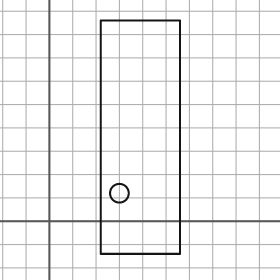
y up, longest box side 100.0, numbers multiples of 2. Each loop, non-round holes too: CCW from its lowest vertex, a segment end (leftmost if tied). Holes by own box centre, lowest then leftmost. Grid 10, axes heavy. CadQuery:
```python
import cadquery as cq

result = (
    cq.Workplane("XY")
    .moveTo(22.0, -14.0)
    .lineTo(56.0, -14.0)
    .lineTo(56.0, 86.0)
    .lineTo(22.0, 86.0)
    .close()
    .moveTo(30.0, 12.0)
    .circle(4.0)
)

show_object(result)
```